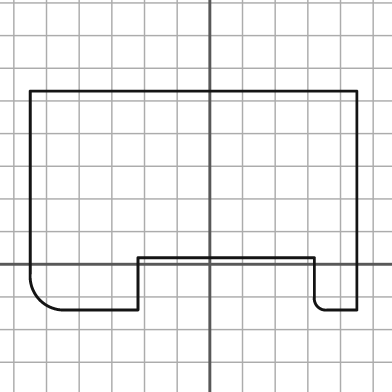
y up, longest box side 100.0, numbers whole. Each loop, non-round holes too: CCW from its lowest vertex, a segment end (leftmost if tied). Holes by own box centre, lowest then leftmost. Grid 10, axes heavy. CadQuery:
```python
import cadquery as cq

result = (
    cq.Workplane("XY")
    .moveTo(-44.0, -14.0)
    .lineTo(-22.0, -14.0)
    .lineTo(-22.0, 2.0)
    .lineTo(32.0, 2.0)
    .lineTo(32.0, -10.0)
    .threePointArc((33.0, -13.0), (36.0, -14.0))
    .lineTo(45.0, -14.0)
    .lineTo(45.0, 53.0)
    .lineTo(-55.0, 53.0)
    .lineTo(-55.0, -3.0)
    .threePointArc((-52.0, -11.0), (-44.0, -14.0))
    .close()
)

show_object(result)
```